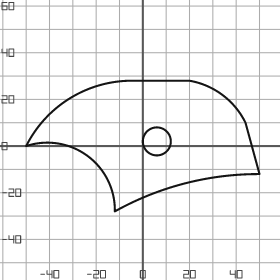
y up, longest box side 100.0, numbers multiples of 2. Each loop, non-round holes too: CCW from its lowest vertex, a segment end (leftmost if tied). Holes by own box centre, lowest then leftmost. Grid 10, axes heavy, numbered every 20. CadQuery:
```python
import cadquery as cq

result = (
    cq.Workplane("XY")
    .moveTo(-12.0, -28.0)
    .threePointArc((18.0, -16.0), (50.0, -12.0))
    .lineTo(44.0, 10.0)
    .threePointArc((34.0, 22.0), (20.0, 28.0))
    .lineTo(-6.0, 28.0)
    .threePointArc((-32.0, 20.0), (-50.0, 0.0))
    .threePointArc((-24.0, -4.0), (-12.0, -28.0))
    .close()
    .moveTo(6.0, 2.0)
    .circle(6.0)
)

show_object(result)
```